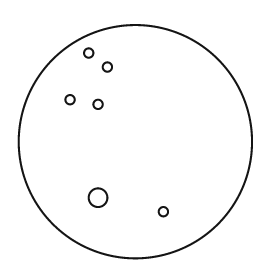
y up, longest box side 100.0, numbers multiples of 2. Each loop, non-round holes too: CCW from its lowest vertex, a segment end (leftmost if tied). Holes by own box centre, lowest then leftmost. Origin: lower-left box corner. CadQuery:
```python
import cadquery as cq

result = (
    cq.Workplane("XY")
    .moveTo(50.0, 50.0)
    .circle(50.0)
    .moveTo(62.0, 20.0)
    .circle(2.0)
    .moveTo(34.0, 26.0)
    .circle(4.0)
    .moveTo(34.0, 66.0)
    .circle(2.0)
    .moveTo(22.0, 68.0)
    .circle(2.0)
    .moveTo(38.0, 82.0)
    .circle(2.0)
    .moveTo(30.0, 88.0)
    .circle(2.0)
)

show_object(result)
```